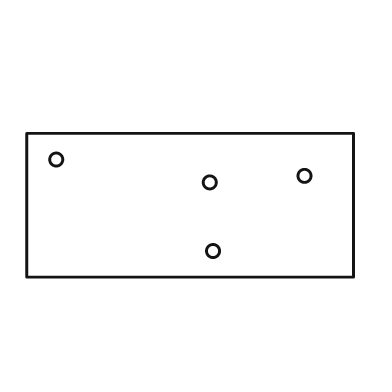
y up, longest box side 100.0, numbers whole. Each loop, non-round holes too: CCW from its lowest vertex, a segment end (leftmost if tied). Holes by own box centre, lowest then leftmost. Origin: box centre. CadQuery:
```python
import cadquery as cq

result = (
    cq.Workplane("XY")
    .moveTo(-50.0, -22.0)
    .lineTo(50.0, -22.0)
    .lineTo(50.0, 22.0)
    .lineTo(-50.0, 22.0)
    .close()
    .moveTo(7.0, -14.0)
    .circle(2.0)
    .moveTo(6.0, 7.0)
    .circle(2.0)
    .moveTo(35.0, 9.0)
    .circle(2.0)
    .moveTo(-41.0, 14.0)
    .circle(2.0)
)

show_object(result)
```